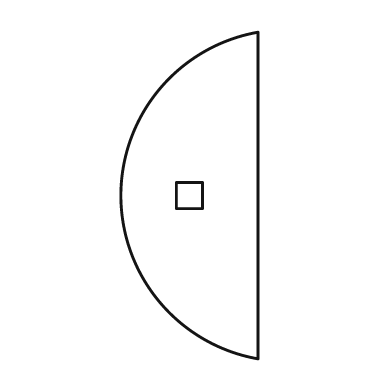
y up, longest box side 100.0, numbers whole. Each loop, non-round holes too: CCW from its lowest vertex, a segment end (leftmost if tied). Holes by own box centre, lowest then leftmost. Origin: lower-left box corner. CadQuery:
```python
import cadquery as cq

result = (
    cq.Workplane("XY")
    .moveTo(42.0, 0.0)
    .lineTo(42.0, 100.0)
    .threePointArc((0.0, 50.0), (42.0, 0.0))
    .close()
    .moveTo(17.0, 46.0)
    .lineTo(25.0, 46.0)
    .lineTo(25.0, 54.0)
    .lineTo(17.0, 54.0)
    .close()
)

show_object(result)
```